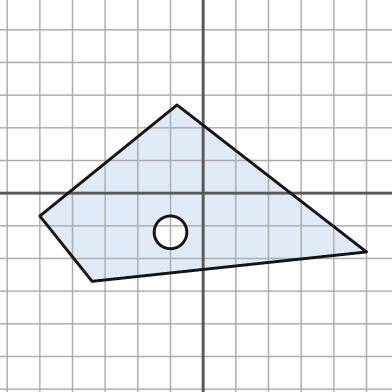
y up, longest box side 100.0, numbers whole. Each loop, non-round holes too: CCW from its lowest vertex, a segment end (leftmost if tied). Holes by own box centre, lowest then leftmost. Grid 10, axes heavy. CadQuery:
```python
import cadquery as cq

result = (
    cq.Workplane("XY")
    .moveTo(-34.0, -27.0)
    .lineTo(50.0, -18.0)
    .lineTo(-8.0, 27.0)
    .lineTo(-50.0, -7.0)
    .close()
    .moveTo(-10.0, -12.0)
    .circle(5.0)
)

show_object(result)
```